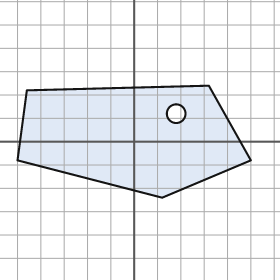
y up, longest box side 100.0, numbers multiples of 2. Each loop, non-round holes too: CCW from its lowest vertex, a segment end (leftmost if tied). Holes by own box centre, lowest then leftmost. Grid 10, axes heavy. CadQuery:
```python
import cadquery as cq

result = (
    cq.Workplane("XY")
    .moveTo(12.0, -24.0)
    .lineTo(50.0, -8.0)
    .lineTo(32.0, 24.0)
    .lineTo(-46.0, 22.0)
    .lineTo(-50.0, -8.0)
    .close()
    .moveTo(18.0, 12.0)
    .circle(4.0)
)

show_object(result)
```